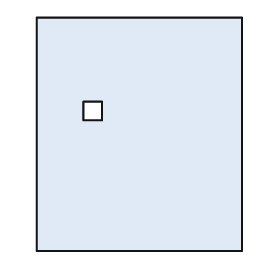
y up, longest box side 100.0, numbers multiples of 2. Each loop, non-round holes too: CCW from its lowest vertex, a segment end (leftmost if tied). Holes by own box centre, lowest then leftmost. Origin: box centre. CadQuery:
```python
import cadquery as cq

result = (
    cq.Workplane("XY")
    .moveTo(-44.0, -50.0)
    .lineTo(44.0, -50.0)
    .lineTo(44.0, 50.0)
    .lineTo(-44.0, 50.0)
    .close()
    .moveTo(-24.0, 6.0)
    .lineTo(-16.0, 6.0)
    .lineTo(-16.0, 14.0)
    .lineTo(-24.0, 14.0)
    .close()
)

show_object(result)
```